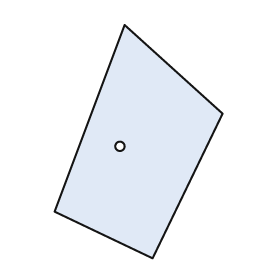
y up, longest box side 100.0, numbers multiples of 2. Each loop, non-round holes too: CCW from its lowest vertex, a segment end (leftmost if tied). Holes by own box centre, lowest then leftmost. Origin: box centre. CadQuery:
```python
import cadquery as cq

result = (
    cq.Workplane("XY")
    .moveTo(6.0, -50.0)
    .lineTo(36.0, 12.0)
    .lineTo(-6.0, 50.0)
    .lineTo(-36.0, -30.0)
    .close()
    .moveTo(-8.0, -2.0)
    .circle(2.0)
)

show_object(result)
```